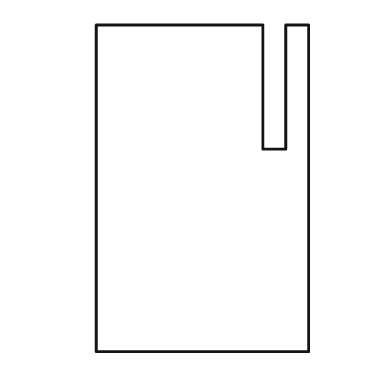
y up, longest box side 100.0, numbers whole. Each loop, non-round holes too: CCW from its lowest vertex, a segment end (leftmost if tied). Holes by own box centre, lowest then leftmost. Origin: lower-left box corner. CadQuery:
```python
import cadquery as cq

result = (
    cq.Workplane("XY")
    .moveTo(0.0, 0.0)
    .lineTo(65.0, 0.0)
    .lineTo(65.0, 100.0)
    .lineTo(58.0, 100.0)
    .lineTo(58.0, 62.0)
    .lineTo(51.0, 62.0)
    .lineTo(51.0, 100.0)
    .lineTo(0.0, 100.0)
    .close()
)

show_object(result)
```